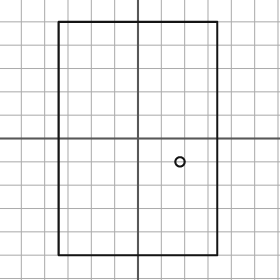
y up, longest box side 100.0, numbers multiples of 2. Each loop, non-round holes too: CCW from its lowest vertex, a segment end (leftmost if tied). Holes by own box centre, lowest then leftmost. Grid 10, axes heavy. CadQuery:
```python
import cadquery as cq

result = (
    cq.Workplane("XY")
    .moveTo(-34.0, -50.0)
    .lineTo(34.0, -50.0)
    .lineTo(34.0, 50.0)
    .lineTo(-34.0, 50.0)
    .close()
    .moveTo(18.0, -10.0)
    .circle(2.0)
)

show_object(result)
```